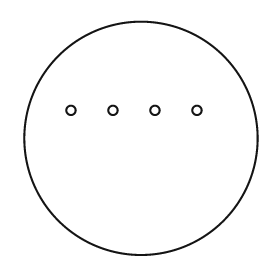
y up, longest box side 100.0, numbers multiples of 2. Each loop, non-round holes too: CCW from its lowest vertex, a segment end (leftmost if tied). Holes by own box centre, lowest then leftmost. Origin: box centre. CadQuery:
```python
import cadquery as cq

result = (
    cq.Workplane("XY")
    .moveTo(0.0, 0.0)
    .circle(50.0)
    .moveTo(-30.0, 12.0)
    .circle(2.0)
    .moveTo(-12.0, 12.0)
    .circle(2.0)
    .moveTo(6.0, 12.0)
    .circle(2.0)
    .moveTo(24.0, 12.0)
    .circle(2.0)
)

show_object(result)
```